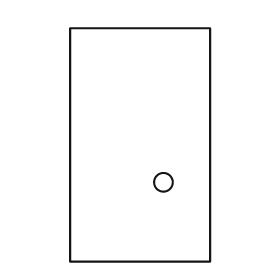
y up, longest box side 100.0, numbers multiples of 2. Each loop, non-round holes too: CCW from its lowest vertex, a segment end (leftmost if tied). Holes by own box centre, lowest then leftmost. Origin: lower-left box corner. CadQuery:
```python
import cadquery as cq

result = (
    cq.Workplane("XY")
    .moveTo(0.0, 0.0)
    .lineTo(60.0, 0.0)
    .lineTo(60.0, 100.0)
    .lineTo(0.0, 100.0)
    .close()
    .moveTo(40.0, 34.0)
    .circle(4.0)
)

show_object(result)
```